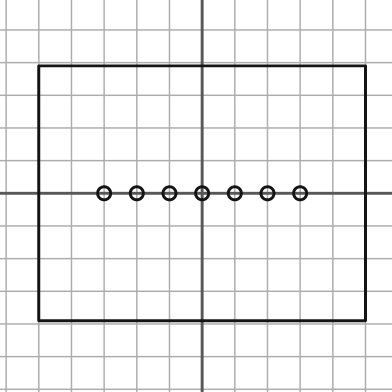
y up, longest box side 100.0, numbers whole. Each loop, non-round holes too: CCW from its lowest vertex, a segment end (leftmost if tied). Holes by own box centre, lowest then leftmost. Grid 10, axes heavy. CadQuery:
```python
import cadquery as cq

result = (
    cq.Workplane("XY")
    .moveTo(-50.0, -39.0)
    .lineTo(50.0, -39.0)
    .lineTo(50.0, 39.0)
    .lineTo(-50.0, 39.0)
    .close()
    .moveTo(-30.0, 0.0)
    .circle(2.0)
    .moveTo(-20.0, 0.0)
    .circle(2.0)
    .moveTo(-10.0, 0.0)
    .circle(2.0)
    .moveTo(0.0, 0.0)
    .circle(2.0)
    .moveTo(10.0, 0.0)
    .circle(2.0)
    .moveTo(20.0, 0.0)
    .circle(2.0)
    .moveTo(30.0, 0.0)
    .circle(2.0)
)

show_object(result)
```